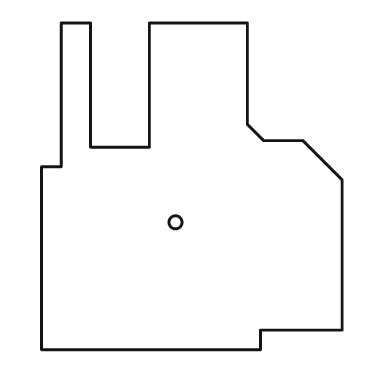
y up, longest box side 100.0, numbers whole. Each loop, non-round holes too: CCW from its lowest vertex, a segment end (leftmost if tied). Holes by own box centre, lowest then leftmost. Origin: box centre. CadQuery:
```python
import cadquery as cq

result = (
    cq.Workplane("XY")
    .moveTo(-46.0, -50.0)
    .lineTo(21.0, -50.0)
    .lineTo(21.0, -44.0)
    .lineTo(46.0, -44.0)
    .lineTo(46.0, 2.0)
    .lineTo(34.0, 14.0)
    .lineTo(22.0, 14.0)
    .lineTo(17.0, 19.0)
    .lineTo(17.0, 50.0)
    .lineTo(-13.0, 50.0)
    .lineTo(-13.0, 12.0)
    .lineTo(-31.0, 12.0)
    .lineTo(-31.0, 50.0)
    .lineTo(-40.0, 50.0)
    .lineTo(-40.0, 6.0)
    .lineTo(-46.0, 6.0)
    .close()
    .moveTo(-5.0, -11.0)
    .circle(2.0)
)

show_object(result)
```